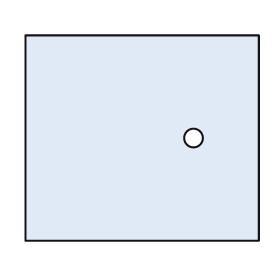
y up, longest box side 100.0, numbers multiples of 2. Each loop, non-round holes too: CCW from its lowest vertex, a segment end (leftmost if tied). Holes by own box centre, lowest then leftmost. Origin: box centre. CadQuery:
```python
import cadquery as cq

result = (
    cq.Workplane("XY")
    .moveTo(-50.0, -44.0)
    .lineTo(50.0, -44.0)
    .lineTo(50.0, 44.0)
    .lineTo(-50.0, 44.0)
    .close()
    .moveTo(22.0, 0.0)
    .circle(4.0)
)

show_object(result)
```